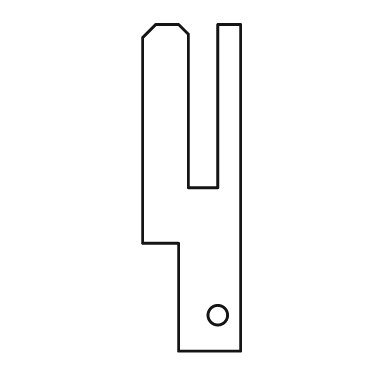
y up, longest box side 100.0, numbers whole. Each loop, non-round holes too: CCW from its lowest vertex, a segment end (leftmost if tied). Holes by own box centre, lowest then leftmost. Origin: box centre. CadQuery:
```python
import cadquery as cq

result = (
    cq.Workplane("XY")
    .moveTo(-4.0, -50.0)
    .lineTo(15.0, -50.0)
    .lineTo(15.0, 50.0)
    .lineTo(8.0, 50.0)
    .lineTo(8.0, 0.0)
    .lineTo(-1.0, 0.0)
    .lineTo(-1.0, 47.0)
    .lineTo(-4.0, 50.0)
    .lineTo(-11.0, 50.0)
    .lineTo(-15.0, 46.0)
    .lineTo(-15.0, -17.0)
    .lineTo(-4.0, -17.0)
    .close()
    .moveTo(8.0, -39.0)
    .circle(3.0)
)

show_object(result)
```